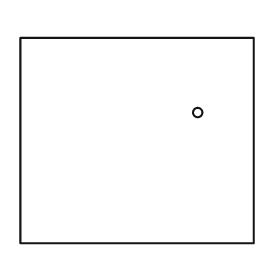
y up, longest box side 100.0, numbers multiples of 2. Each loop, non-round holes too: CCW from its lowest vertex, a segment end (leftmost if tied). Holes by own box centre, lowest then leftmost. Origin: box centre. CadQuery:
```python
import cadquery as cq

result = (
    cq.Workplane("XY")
    .moveTo(-50.0, -44.0)
    .lineTo(50.0, -44.0)
    .lineTo(50.0, 44.0)
    .lineTo(-50.0, 44.0)
    .close()
    .moveTo(26.0, 12.0)
    .circle(2.0)
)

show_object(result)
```